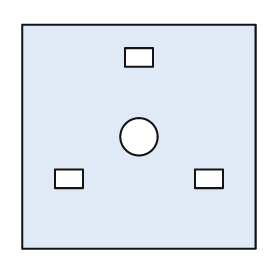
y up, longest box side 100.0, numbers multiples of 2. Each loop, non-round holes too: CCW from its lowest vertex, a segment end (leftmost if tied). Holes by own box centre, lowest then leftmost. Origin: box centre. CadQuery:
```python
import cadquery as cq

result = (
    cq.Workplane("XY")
    .moveTo(-50.0, -48.0)
    .lineTo(50.0, -48.0)
    .lineTo(50.0, 48.0)
    .lineTo(-50.0, 48.0)
    .close()
    .moveTo(-36.0, -22.0)
    .lineTo(-24.0, -22.0)
    .lineTo(-24.0, -14.0)
    .lineTo(-36.0, -14.0)
    .close()
    .moveTo(24.0, -22.0)
    .lineTo(36.0, -22.0)
    .lineTo(36.0, -14.0)
    .lineTo(24.0, -14.0)
    .close()
    .moveTo(0.0, 0.0)
    .circle(8.0)
    .moveTo(-6.0, 30.0)
    .lineTo(6.0, 30.0)
    .lineTo(6.0, 38.0)
    .lineTo(-6.0, 38.0)
    .close()
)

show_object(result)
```